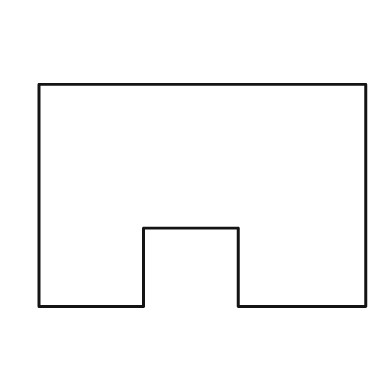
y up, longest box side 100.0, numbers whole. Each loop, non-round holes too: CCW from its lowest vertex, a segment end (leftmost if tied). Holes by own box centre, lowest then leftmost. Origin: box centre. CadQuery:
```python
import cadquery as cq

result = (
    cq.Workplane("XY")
    .moveTo(-50.0, -34.0)
    .lineTo(-18.0, -34.0)
    .lineTo(-18.0, -10.0)
    .lineTo(11.0, -10.0)
    .lineTo(11.0, -34.0)
    .lineTo(50.0, -34.0)
    .lineTo(50.0, 34.0)
    .lineTo(-50.0, 34.0)
    .close()
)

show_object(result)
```